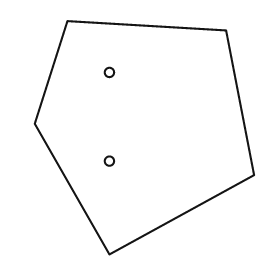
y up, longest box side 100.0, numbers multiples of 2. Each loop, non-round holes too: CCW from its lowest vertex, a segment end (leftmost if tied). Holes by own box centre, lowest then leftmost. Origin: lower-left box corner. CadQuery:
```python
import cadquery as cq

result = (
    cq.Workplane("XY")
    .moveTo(32.0, 0.0)
    .lineTo(94.0, 34.0)
    .lineTo(82.0, 96.0)
    .lineTo(14.0, 100.0)
    .lineTo(0.0, 56.0)
    .close()
    .moveTo(32.0, 40.0)
    .circle(2.0)
    .moveTo(32.0, 78.0)
    .circle(2.0)
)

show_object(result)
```